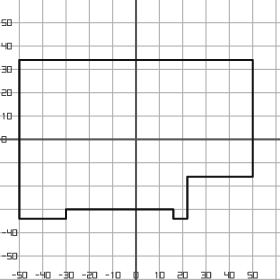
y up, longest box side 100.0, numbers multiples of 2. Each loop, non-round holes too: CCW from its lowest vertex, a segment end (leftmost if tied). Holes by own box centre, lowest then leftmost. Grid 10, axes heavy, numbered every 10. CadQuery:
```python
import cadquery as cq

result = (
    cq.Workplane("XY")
    .moveTo(-50.0, -34.0)
    .lineTo(-30.0, -34.0)
    .lineTo(-30.0, -30.0)
    .lineTo(16.0, -30.0)
    .lineTo(16.0, -34.0)
    .lineTo(22.0, -34.0)
    .lineTo(22.0, -16.0)
    .lineTo(50.0, -16.0)
    .lineTo(50.0, 34.0)
    .lineTo(-50.0, 34.0)
    .close()
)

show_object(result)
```